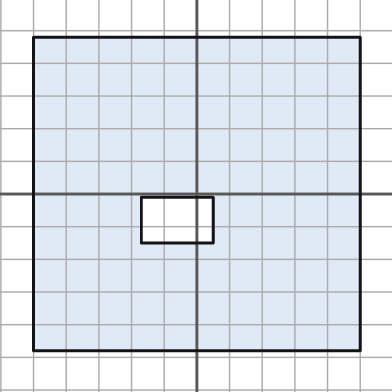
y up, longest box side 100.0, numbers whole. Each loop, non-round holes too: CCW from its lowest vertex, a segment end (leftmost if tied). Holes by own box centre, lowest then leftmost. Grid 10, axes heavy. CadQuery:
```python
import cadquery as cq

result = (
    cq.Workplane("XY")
    .moveTo(-50.0, -48.0)
    .lineTo(50.0, -48.0)
    .lineTo(50.0, 48.0)
    .lineTo(-50.0, 48.0)
    .close()
    .moveTo(-17.0, -15.0)
    .lineTo(5.0, -15.0)
    .lineTo(5.0, -1.0)
    .lineTo(-17.0, -1.0)
    .close()
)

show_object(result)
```